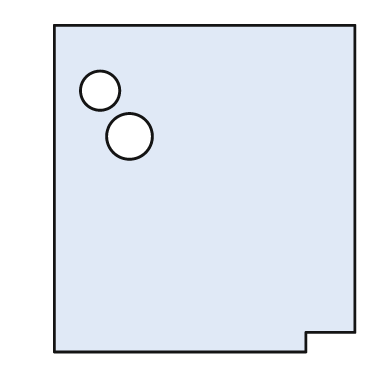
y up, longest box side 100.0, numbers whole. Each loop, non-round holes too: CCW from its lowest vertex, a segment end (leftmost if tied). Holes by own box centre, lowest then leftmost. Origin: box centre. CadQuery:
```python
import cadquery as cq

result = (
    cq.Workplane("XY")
    .moveTo(-46.0, -50.0)
    .lineTo(31.0, -50.0)
    .lineTo(31.0, -44.0)
    .lineTo(46.0, -44.0)
    .lineTo(46.0, 50.0)
    .lineTo(-46.0, 50.0)
    .close()
    .moveTo(-23.0, 16.0)
    .circle(7.0)
    .moveTo(-32.0, 30.0)
    .circle(6.0)
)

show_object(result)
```